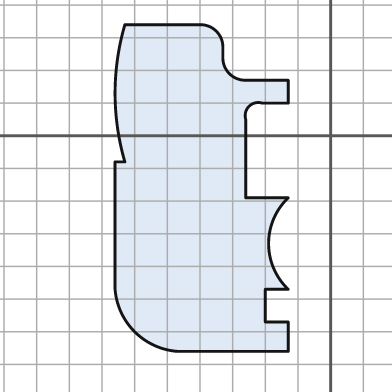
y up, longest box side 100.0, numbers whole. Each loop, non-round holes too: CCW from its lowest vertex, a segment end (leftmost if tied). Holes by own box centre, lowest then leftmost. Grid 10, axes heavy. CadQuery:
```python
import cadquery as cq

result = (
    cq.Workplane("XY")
    .moveTo(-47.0, -66.0)
    .lineTo(-13.0, -66.0)
    .lineTo(-13.0, -57.0)
    .lineTo(-20.0, -57.0)
    .lineTo(-20.0, -47.0)
    .lineTo(-13.0, -47.0)
    .threePointArc((-19.0, -33.0), (-13.0, -19.0))
    .lineTo(-26.0, -19.0)
    .lineTo(-26.0, 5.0)
    .threePointArc((-25.0, 9.0), (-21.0, 10.0))
    .lineTo(-13.0, 10.0)
    .lineTo(-13.0, 17.0)
    .lineTo(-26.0, 17.0)
    .threePointArc((-31.0, 19.0), (-33.0, 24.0))
    .lineTo(-33.0, 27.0)
    .threePointArc((-35.0, 32.0), (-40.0, 34.0))
    .lineTo(-63.0, 34.0)
    .threePointArc((-66.0, 13.0), (-63.0, -8.0))
    .lineTo(-66.0, -8.0)
    .lineTo(-66.0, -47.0)
    .threePointArc((-60.0, -60.0), (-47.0, -66.0))
    .close()
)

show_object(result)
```